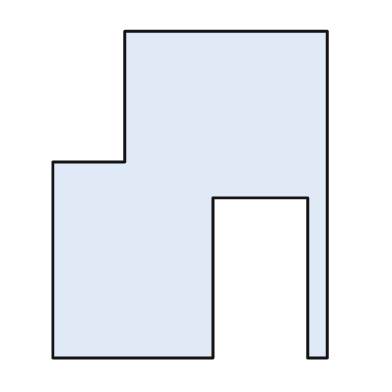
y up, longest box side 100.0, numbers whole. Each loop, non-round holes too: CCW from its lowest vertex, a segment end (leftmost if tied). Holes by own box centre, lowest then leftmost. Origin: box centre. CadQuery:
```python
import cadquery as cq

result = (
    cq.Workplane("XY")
    .moveTo(-42.0, -50.0)
    .lineTo(7.0, -50.0)
    .lineTo(7.0, -1.0)
    .lineTo(36.0, -1.0)
    .lineTo(36.0, -50.0)
    .lineTo(42.0, -50.0)
    .lineTo(42.0, 50.0)
    .lineTo(-20.0, 50.0)
    .lineTo(-20.0, 10.0)
    .lineTo(-42.0, 10.0)
    .close()
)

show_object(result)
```